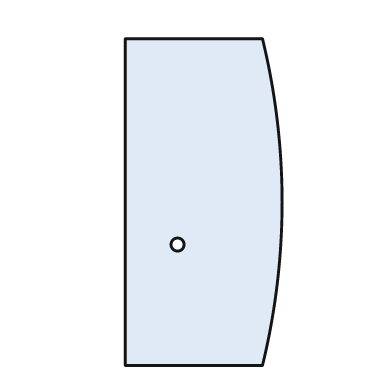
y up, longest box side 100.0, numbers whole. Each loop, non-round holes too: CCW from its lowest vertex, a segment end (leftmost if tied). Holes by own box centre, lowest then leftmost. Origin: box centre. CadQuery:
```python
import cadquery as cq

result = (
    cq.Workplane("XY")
    .moveTo(-24.0, -50.0)
    .lineTo(18.0, -50.0)
    .threePointArc((24.0, 0.0), (18.0, 50.0))
    .lineTo(-24.0, 50.0)
    .close()
    .moveTo(-8.0, -13.0)
    .circle(2.0)
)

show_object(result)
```